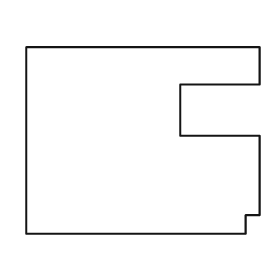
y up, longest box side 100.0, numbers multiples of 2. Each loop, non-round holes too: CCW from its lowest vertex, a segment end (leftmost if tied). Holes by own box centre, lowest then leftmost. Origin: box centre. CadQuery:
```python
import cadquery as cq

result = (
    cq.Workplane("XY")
    .moveTo(-50.0, -40.0)
    .lineTo(44.0, -40.0)
    .lineTo(44.0, -32.0)
    .lineTo(50.0, -32.0)
    .lineTo(50.0, 2.0)
    .lineTo(16.0, 2.0)
    .lineTo(16.0, 24.0)
    .lineTo(50.0, 24.0)
    .lineTo(50.0, 40.0)
    .lineTo(-50.0, 40.0)
    .close()
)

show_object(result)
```